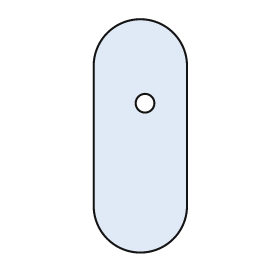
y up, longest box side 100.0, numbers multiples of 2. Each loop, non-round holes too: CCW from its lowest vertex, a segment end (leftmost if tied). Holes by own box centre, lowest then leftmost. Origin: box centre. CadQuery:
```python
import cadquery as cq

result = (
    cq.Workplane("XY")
    .moveTo(-20.0, -30.0)
    .threePointArc((0.0, -50.0), (20.0, -30.0))
    .lineTo(20.0, 30.0)
    .threePointArc((0.0, 50.0), (-20.0, 30.0))
    .close()
    .moveTo(2.0, 14.0)
    .circle(4.0)
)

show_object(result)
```